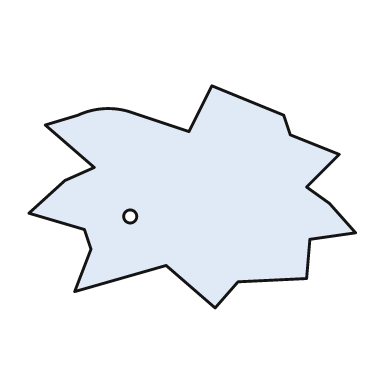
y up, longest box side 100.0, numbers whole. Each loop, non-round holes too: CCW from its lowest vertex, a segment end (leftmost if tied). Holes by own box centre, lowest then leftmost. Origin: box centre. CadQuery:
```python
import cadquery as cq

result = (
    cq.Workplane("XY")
    .moveTo(7.0, -34.0)
    .lineTo(14.0, -26.0)
    .lineTo(35.0, -25.0)
    .lineTo(36.0, -13.0)
    .lineTo(50.0, -11.0)
    .lineTo(42.0, -2.0)
    .lineTo(35.0, 3.0)
    .lineTo(45.0, 13.0)
    .lineTo(30.0, 19.0)
    .lineTo(28.0, 25.0)
    .lineTo(6.0, 34.0)
    .lineTo(-1.0, 20.0)
    .lineTo(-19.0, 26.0)
    .threePointArc((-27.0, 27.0), (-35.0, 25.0))
    .lineTo(-45.0, 22.0)
    .lineTo(-30.0, 9.0)
    .lineTo(-39.0, 5.0)
    .lineTo(-50.0, -5.0)
    .lineTo(-33.0, -10.0)
    .lineTo(-31.0, -16.0)
    .lineTo(-36.0, -29.0)
    .lineTo(-8.0, -21.0)
    .close()
    .moveTo(-19.0, -6.0)
    .circle(2.0)
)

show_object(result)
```